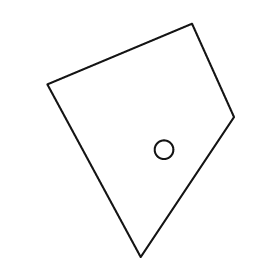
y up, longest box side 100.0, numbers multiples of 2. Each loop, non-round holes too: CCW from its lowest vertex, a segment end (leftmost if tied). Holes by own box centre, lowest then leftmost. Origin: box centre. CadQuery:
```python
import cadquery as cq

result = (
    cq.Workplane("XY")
    .moveTo(0.0, -50.0)
    .lineTo(40.0, 10.0)
    .lineTo(22.0, 50.0)
    .lineTo(-40.0, 24.0)
    .close()
    .moveTo(10.0, -4.0)
    .circle(4.0)
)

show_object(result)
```